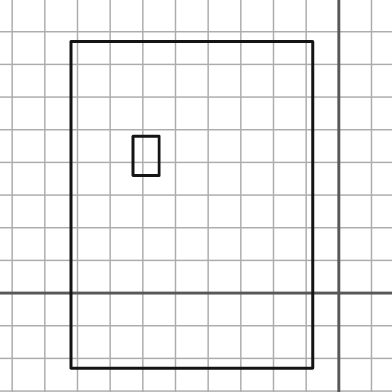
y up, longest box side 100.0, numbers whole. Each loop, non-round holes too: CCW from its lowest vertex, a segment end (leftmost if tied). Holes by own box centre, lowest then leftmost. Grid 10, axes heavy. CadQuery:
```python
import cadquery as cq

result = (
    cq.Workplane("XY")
    .moveTo(-82.0, -23.0)
    .lineTo(-8.0, -23.0)
    .lineTo(-8.0, 77.0)
    .lineTo(-82.0, 77.0)
    .close()
    .moveTo(-63.0, 36.0)
    .lineTo(-55.0, 36.0)
    .lineTo(-55.0, 48.0)
    .lineTo(-63.0, 48.0)
    .close()
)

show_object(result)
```